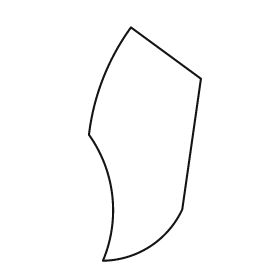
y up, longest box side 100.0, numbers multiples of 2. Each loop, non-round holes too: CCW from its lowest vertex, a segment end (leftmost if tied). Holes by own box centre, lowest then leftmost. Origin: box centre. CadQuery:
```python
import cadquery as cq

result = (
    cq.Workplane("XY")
    .moveTo(-18.0, -50.0)
    .threePointArc((2.0, -44.0), (16.0, -28.0))
    .lineTo(24.0, 28.0)
    .lineTo(-6.0, 50.0)
    .threePointArc((-18.0, 28.0), (-24.0, 4.0))
    .threePointArc((-14.0, -22.0), (-18.0, -50.0))
    .close()
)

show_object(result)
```